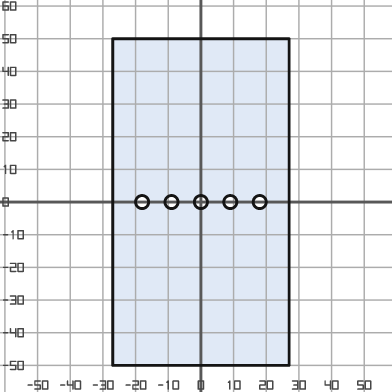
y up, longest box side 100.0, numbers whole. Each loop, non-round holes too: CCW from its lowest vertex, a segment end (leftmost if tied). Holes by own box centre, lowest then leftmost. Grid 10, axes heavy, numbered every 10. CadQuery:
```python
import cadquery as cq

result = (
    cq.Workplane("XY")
    .moveTo(-27.0, -50.0)
    .lineTo(27.0, -50.0)
    .lineTo(27.0, 50.0)
    .lineTo(-27.0, 50.0)
    .close()
    .moveTo(-18.0, 0.0)
    .circle(2.0)
    .moveTo(-9.0, 0.0)
    .circle(2.0)
    .moveTo(0.0, 0.0)
    .circle(2.0)
    .moveTo(9.0, 0.0)
    .circle(2.0)
    .moveTo(18.0, 0.0)
    .circle(2.0)
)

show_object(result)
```